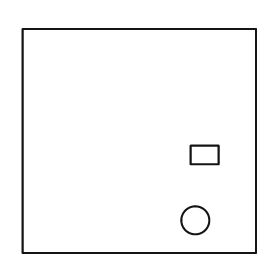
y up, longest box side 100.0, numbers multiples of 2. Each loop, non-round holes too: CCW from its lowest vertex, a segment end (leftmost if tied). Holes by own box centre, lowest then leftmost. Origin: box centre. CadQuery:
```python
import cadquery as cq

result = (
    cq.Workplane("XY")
    .moveTo(-50.0, -48.0)
    .lineTo(50.0, -48.0)
    .lineTo(50.0, 48.0)
    .lineTo(-50.0, 48.0)
    .close()
    .moveTo(24.0, -34.0)
    .circle(6.0)
    .moveTo(22.0, -10.0)
    .lineTo(34.0, -10.0)
    .lineTo(34.0, -2.0)
    .lineTo(22.0, -2.0)
    .close()
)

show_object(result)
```